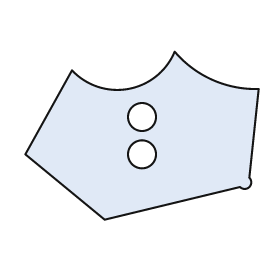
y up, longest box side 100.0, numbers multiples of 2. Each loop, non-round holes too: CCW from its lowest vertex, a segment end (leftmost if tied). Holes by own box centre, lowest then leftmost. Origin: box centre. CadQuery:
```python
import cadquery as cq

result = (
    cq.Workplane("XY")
    .moveTo(-16.0, -36.0)
    .lineTo(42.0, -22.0)
    .threePointArc((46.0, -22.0), (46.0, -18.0))
    .lineTo(50.0, 20.0)
    .threePointArc((30.0, 24.0), (14.0, 36.0))
    .threePointArc((-6.0, 20.0), (-30.0, 28.0))
    .lineTo(-50.0, -8.0)
    .close()
    .moveTo(0.0, -8.0)
    .circle(6.0)
    .moveTo(0.0, 8.0)
    .circle(6.0)
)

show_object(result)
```